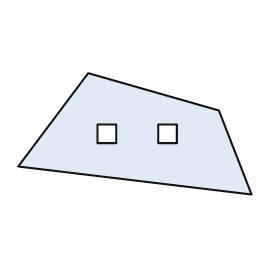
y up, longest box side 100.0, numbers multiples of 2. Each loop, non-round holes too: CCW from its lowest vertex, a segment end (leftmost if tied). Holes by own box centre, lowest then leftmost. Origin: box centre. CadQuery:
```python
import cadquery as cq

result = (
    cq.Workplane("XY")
    .moveTo(50.0, -26.0)
    .lineTo(36.0, 10.0)
    .lineTo(-20.0, 26.0)
    .lineTo(-50.0, -14.0)
    .close()
    .moveTo(-16.0, -4.0)
    .lineTo(-8.0, -4.0)
    .lineTo(-8.0, 4.0)
    .lineTo(-16.0, 4.0)
    .close()
    .moveTo(10.0, -4.0)
    .lineTo(18.0, -4.0)
    .lineTo(18.0, 4.0)
    .lineTo(10.0, 4.0)
    .close()
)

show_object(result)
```